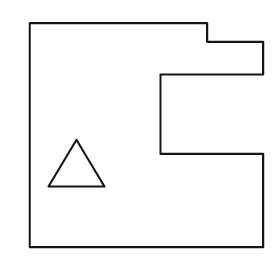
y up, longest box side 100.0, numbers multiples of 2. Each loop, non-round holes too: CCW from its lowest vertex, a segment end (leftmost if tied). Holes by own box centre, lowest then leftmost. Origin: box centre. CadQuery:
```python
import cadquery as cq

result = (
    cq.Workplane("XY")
    .moveTo(-50.0, -48.0)
    .lineTo(50.0, -48.0)
    .lineTo(50.0, -8.0)
    .lineTo(6.0, -8.0)
    .lineTo(6.0, 26.0)
    .lineTo(50.0, 26.0)
    .lineTo(50.0, 40.0)
    .lineTo(26.0, 40.0)
    .lineTo(26.0, 48.0)
    .lineTo(-50.0, 48.0)
    .close()
    .moveTo(-42.0, -22.0)
    .lineTo(-18.0, -22.0)
    .lineTo(-30.0, -2.0)
    .close()
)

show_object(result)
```